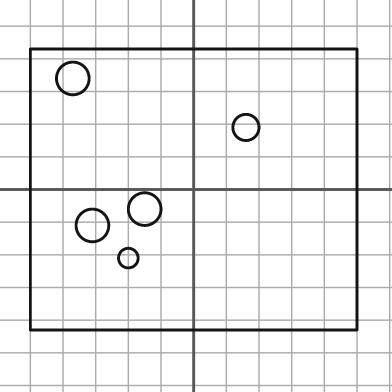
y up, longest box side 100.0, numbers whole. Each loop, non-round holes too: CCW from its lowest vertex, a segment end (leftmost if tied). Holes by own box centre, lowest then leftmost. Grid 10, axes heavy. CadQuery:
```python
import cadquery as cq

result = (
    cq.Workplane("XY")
    .moveTo(-50.0, -43.0)
    .lineTo(50.0, -43.0)
    .lineTo(50.0, 43.0)
    .lineTo(-50.0, 43.0)
    .close()
    .moveTo(-20.0, -21.0)
    .circle(3.0)
    .moveTo(-31.0, -11.0)
    .circle(5.0)
    .moveTo(-15.0, -6.0)
    .circle(5.0)
    .moveTo(16.0, 19.0)
    .circle(4.0)
    .moveTo(-37.0, 34.0)
    .circle(5.0)
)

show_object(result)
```